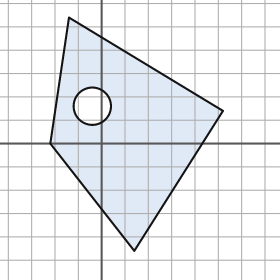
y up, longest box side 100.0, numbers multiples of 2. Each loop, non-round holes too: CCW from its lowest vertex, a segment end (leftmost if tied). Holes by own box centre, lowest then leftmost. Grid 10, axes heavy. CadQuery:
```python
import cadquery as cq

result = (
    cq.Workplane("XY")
    .moveTo(14.0, -46.0)
    .lineTo(52.0, 14.0)
    .lineTo(-14.0, 54.0)
    .lineTo(-22.0, 0.0)
    .close()
    .moveTo(-4.0, 16.0)
    .circle(8.0)
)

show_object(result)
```